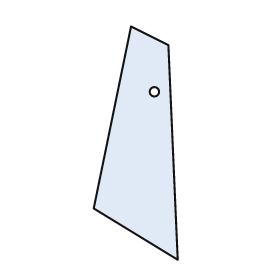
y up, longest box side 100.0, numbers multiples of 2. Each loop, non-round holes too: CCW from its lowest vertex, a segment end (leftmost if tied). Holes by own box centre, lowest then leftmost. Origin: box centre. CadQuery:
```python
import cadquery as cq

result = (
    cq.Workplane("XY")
    .moveTo(18.0, -50.0)
    .lineTo(14.0, 42.0)
    .lineTo(-2.0, 50.0)
    .lineTo(-18.0, -28.0)
    .close()
    .moveTo(8.0, 22.0)
    .circle(2.0)
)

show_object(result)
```